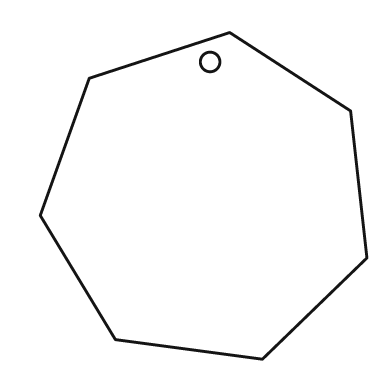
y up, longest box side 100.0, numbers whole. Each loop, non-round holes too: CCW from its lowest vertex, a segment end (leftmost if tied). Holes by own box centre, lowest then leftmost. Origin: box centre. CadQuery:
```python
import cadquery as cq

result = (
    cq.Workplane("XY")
    .moveTo(18.0, -50.0)
    .lineTo(50.0, -19.0)
    .lineTo(45.0, 26.0)
    .lineTo(8.0, 50.0)
    .lineTo(-35.0, 36.0)
    .lineTo(-50.0, -6.0)
    .lineTo(-27.0, -44.0)
    .close()
    .moveTo(2.0, 41.0)
    .circle(3.0)
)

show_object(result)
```